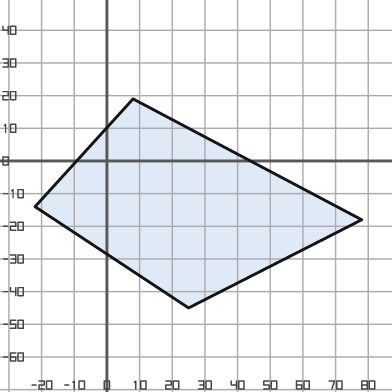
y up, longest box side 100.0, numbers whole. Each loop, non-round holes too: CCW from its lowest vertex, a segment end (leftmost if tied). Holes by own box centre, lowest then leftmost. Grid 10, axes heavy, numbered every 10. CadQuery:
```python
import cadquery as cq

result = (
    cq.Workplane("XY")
    .moveTo(25.0, -45.0)
    .lineTo(78.0, -18.0)
    .lineTo(8.0, 19.0)
    .lineTo(-22.0, -14.0)
    .close()
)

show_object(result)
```